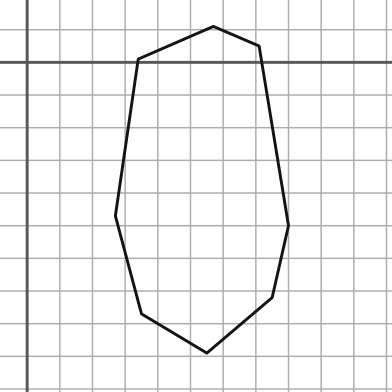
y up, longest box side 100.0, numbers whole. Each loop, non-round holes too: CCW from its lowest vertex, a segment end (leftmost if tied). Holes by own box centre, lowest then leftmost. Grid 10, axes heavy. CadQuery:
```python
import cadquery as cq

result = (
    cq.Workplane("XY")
    .moveTo(55.0, -89.0)
    .lineTo(75.0, -72.0)
    .lineTo(80.0, -50.0)
    .lineTo(71.0, 5.0)
    .lineTo(57.0, 11.0)
    .lineTo(34.0, 1.0)
    .lineTo(27.0, -47.0)
    .lineTo(35.0, -77.0)
    .close()
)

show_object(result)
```